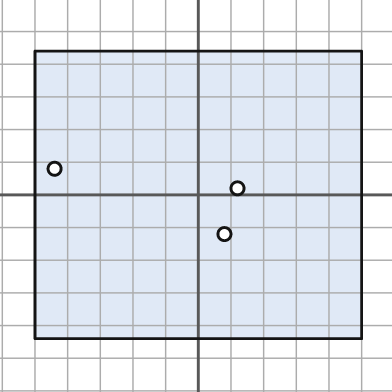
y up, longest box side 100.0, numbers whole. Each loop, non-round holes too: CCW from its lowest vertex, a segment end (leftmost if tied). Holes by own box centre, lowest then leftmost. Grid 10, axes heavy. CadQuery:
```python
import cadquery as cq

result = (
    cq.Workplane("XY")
    .moveTo(-50.0, -44.0)
    .lineTo(50.0, -44.0)
    .lineTo(50.0, 44.0)
    .lineTo(-50.0, 44.0)
    .close()
    .moveTo(8.0, -12.0)
    .circle(2.0)
    .moveTo(12.0, 2.0)
    .circle(2.0)
    .moveTo(-44.0, 8.0)
    .circle(2.0)
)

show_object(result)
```